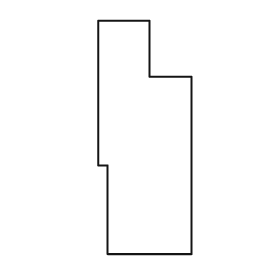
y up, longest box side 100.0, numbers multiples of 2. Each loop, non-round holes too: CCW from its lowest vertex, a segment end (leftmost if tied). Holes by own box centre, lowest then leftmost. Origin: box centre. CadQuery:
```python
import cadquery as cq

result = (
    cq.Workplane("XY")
    .moveTo(-16.0, -50.0)
    .lineTo(20.0, -50.0)
    .lineTo(20.0, 26.0)
    .lineTo(2.0, 26.0)
    .lineTo(2.0, 50.0)
    .lineTo(-20.0, 50.0)
    .lineTo(-20.0, -12.0)
    .lineTo(-16.0, -12.0)
    .close()
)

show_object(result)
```